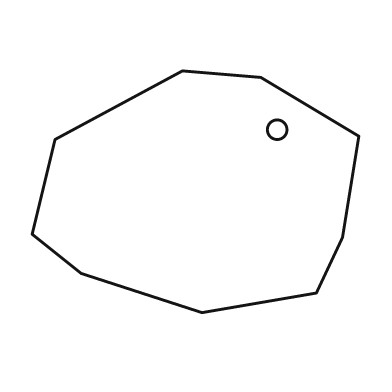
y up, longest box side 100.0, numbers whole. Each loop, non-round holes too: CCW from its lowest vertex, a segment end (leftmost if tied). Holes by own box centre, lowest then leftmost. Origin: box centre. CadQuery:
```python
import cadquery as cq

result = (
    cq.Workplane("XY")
    .moveTo(2.0, -37.0)
    .lineTo(37.0, -31.0)
    .lineTo(45.0, -14.0)
    .lineTo(50.0, 17.0)
    .lineTo(20.0, 35.0)
    .lineTo(-4.0, 37.0)
    .lineTo(-43.0, 16.0)
    .lineTo(-50.0, -13.0)
    .lineTo(-35.0, -25.0)
    .close()
    .moveTo(25.0, 19.0)
    .circle(3.0)
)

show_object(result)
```